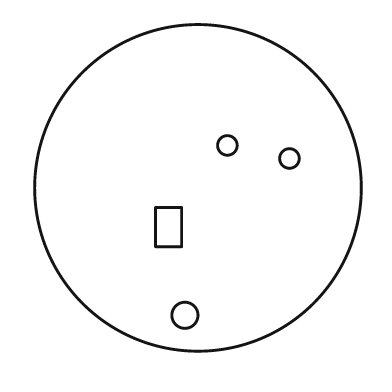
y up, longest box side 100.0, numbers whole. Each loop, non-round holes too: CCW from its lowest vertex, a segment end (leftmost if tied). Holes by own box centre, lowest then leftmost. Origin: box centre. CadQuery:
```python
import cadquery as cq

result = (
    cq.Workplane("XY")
    .moveTo(0.0, 0.0)
    .circle(50.0)
    .moveTo(-4.0, -39.0)
    .circle(4.0)
    .moveTo(-13.0, -18.0)
    .lineTo(-5.0, -18.0)
    .lineTo(-5.0, -6.0)
    .lineTo(-13.0, -6.0)
    .close()
    .moveTo(28.0, 9.0)
    .circle(3.0)
    .moveTo(9.0, 13.0)
    .circle(3.0)
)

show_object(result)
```